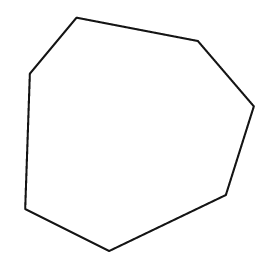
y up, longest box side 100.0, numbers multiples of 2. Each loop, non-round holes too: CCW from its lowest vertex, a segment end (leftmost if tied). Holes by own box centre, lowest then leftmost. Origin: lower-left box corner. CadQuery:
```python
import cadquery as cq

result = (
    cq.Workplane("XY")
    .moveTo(36.0, 0.0)
    .lineTo(86.0, 24.0)
    .lineTo(98.0, 62.0)
    .lineTo(74.0, 90.0)
    .lineTo(22.0, 100.0)
    .lineTo(2.0, 76.0)
    .lineTo(0.0, 18.0)
    .close()
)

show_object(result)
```